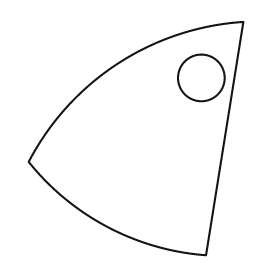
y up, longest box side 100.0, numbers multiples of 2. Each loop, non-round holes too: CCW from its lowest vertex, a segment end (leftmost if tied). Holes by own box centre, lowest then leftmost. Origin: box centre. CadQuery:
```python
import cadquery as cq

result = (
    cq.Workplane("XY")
    .moveTo(30.0, -50.0)
    .lineTo(46.0, 50.0)
    .threePointArc((-8.0, 32.0), (-46.0, -10.0))
    .threePointArc((-12.0, -38.0), (30.0, -50.0))
    .close()
    .moveTo(28.0, 26.0)
    .circle(10.0)
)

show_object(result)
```